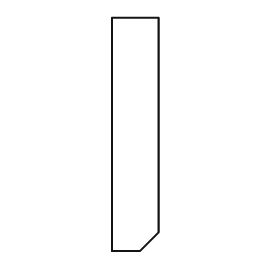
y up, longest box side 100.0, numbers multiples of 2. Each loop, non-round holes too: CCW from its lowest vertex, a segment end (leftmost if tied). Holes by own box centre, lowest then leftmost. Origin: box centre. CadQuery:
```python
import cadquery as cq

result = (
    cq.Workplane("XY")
    .moveTo(-10.0, -50.0)
    .lineTo(2.0, -50.0)
    .lineTo(10.0, -42.0)
    .lineTo(10.0, 50.0)
    .lineTo(-10.0, 50.0)
    .close()
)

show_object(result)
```